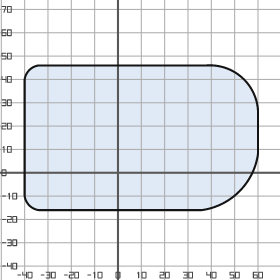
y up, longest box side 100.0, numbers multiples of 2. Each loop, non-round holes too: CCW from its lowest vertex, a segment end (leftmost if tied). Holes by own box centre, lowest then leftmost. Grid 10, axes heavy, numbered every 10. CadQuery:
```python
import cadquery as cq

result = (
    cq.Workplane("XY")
    .moveTo(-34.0, -16.0)
    .lineTo(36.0, -16.0)
    .threePointArc((52.0, -8.0), (60.0, 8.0))
    .lineTo(60.0, 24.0)
    .threePointArc((54.0, 40.0), (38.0, 46.0))
    .lineTo(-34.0, 46.0)
    .threePointArc((-38.0, 44.0), (-40.0, 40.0))
    .lineTo(-40.0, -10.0)
    .threePointArc((-38.0, -14.0), (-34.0, -16.0))
    .close()
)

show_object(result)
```